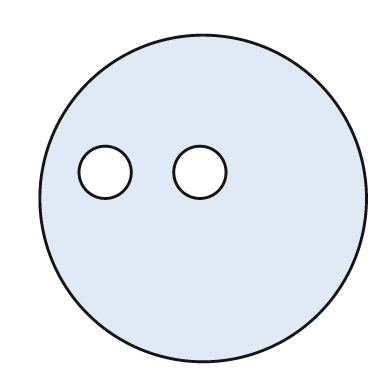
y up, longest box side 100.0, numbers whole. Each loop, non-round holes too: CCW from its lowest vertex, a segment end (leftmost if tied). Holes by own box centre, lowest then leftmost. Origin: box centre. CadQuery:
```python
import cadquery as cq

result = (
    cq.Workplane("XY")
    .moveTo(0.0, 0.0)
    .circle(50.0)
    .moveTo(-30.0, 8.0)
    .circle(8.0)
    .moveTo(-1.0, 8.0)
    .circle(8.0)
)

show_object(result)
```